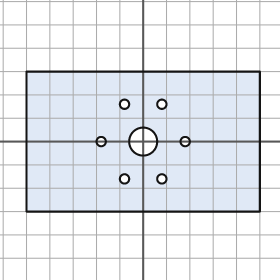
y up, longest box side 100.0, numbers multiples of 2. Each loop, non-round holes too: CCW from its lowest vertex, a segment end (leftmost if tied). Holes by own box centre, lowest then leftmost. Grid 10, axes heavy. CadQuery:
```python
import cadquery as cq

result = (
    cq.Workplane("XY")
    .moveTo(-50.0, -30.0)
    .lineTo(50.0, -30.0)
    .lineTo(50.0, 30.0)
    .lineTo(-50.0, 30.0)
    .close()
    .moveTo(-8.0, -16.0)
    .circle(2.0)
    .moveTo(8.0, -16.0)
    .circle(2.0)
    .moveTo(-18.0, 0.0)
    .circle(2.0)
    .moveTo(0.0, 0.0)
    .circle(6.0)
    .moveTo(18.0, 0.0)
    .circle(2.0)
    .moveTo(-8.0, 16.0)
    .circle(2.0)
    .moveTo(8.0, 16.0)
    .circle(2.0)
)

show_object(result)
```